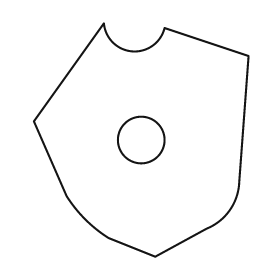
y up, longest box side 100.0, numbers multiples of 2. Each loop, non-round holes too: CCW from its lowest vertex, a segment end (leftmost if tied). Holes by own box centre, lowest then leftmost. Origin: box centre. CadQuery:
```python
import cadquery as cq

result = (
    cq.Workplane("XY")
    .moveTo(6.0, -50.0)
    .lineTo(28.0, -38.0)
    .threePointArc((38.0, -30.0), (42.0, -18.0))
    .lineTo(46.0, 36.0)
    .lineTo(10.0, 48.0)
    .threePointArc((-4.0, 38.0), (-16.0, 50.0))
    .lineTo(-46.0, 8.0)
    .lineTo(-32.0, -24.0)
    .threePointArc((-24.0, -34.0), (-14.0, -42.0))
    .close()
    .moveTo(0.0, 0.0)
    .circle(10.0)
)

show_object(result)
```